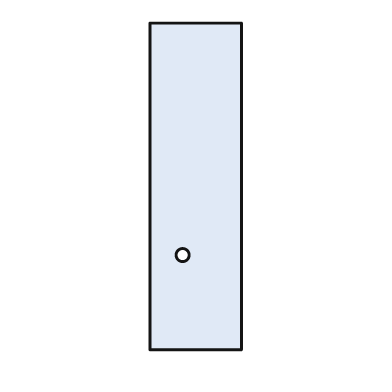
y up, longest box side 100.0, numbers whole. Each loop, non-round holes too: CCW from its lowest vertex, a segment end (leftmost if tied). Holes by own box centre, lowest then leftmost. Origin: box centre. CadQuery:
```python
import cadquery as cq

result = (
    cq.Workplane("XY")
    .moveTo(-14.0, -50.0)
    .lineTo(14.0, -50.0)
    .lineTo(14.0, 50.0)
    .lineTo(-14.0, 50.0)
    .close()
    .moveTo(-4.0, -21.0)
    .circle(2.0)
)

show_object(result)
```